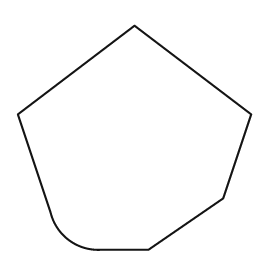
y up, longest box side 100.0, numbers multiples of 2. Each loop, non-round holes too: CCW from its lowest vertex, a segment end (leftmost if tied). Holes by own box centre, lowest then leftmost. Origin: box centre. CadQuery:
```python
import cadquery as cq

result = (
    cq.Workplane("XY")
    .moveTo(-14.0, -48.0)
    .lineTo(6.0, -48.0)
    .lineTo(38.0, -26.0)
    .lineTo(50.0, 10.0)
    .lineTo(0.0, 48.0)
    .lineTo(-50.0, 10.0)
    .lineTo(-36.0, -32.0)
    .threePointArc((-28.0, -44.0), (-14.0, -48.0))
    .close()
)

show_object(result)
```